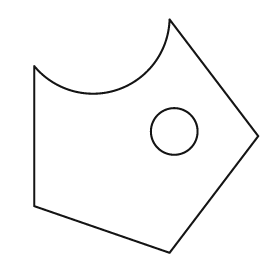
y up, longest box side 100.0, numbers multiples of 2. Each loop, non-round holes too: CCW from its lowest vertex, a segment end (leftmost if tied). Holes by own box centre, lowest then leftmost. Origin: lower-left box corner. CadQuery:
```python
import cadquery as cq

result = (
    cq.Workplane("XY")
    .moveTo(58.0, 0.0)
    .lineTo(96.0, 50.0)
    .lineTo(58.0, 100.0)
    .threePointArc((36.0, 70.0), (0.0, 80.0))
    .lineTo(0.0, 20.0)
    .close()
    .moveTo(60.0, 52.0)
    .circle(10.0)
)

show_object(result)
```